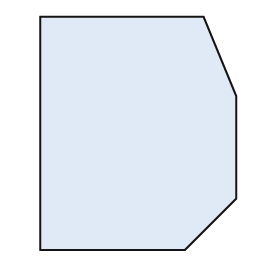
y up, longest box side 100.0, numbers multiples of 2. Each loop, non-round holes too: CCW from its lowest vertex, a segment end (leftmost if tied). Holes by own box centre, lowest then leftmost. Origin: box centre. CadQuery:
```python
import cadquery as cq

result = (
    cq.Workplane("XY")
    .moveTo(-42.0, -50.0)
    .lineTo(20.0, -50.0)
    .lineTo(42.0, -28.0)
    .lineTo(42.0, 16.0)
    .lineTo(28.0, 50.0)
    .lineTo(-42.0, 50.0)
    .close()
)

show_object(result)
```